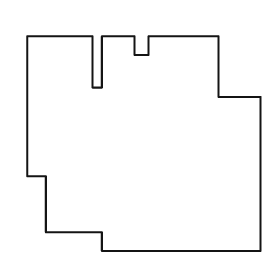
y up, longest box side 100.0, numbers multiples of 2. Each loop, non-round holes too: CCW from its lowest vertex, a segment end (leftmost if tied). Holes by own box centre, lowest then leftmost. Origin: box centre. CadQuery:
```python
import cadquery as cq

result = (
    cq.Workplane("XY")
    .moveTo(-18.0, -46.0)
    .lineTo(50.0, -46.0)
    .lineTo(50.0, 20.0)
    .lineTo(32.0, 20.0)
    .lineTo(32.0, 46.0)
    .lineTo(2.0, 46.0)
    .lineTo(2.0, 38.0)
    .lineTo(-4.0, 38.0)
    .lineTo(-4.0, 46.0)
    .lineTo(-18.0, 46.0)
    .lineTo(-18.0, 24.0)
    .lineTo(-22.0, 24.0)
    .lineTo(-22.0, 46.0)
    .lineTo(-50.0, 46.0)
    .lineTo(-50.0, -14.0)
    .lineTo(-42.0, -14.0)
    .lineTo(-42.0, -38.0)
    .lineTo(-18.0, -38.0)
    .close()
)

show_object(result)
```